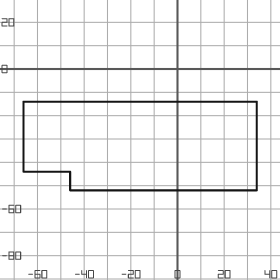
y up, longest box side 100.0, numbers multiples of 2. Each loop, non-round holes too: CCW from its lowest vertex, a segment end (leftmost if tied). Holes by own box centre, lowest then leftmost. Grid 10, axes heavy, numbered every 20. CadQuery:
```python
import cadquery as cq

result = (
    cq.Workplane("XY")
    .moveTo(-46.0, -52.0)
    .lineTo(34.0, -52.0)
    .lineTo(34.0, -14.0)
    .lineTo(-66.0, -14.0)
    .lineTo(-66.0, -44.0)
    .lineTo(-46.0, -44.0)
    .close()
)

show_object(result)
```